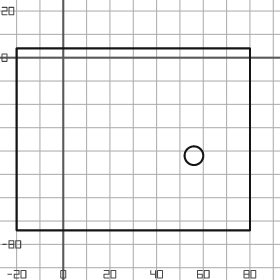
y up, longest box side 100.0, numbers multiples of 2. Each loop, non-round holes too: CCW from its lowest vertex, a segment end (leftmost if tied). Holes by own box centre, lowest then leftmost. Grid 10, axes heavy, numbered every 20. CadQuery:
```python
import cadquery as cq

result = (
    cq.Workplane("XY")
    .moveTo(-20.0, -74.0)
    .lineTo(80.0, -74.0)
    .lineTo(80.0, 4.0)
    .lineTo(-20.0, 4.0)
    .close()
    .moveTo(56.0, -42.0)
    .circle(4.0)
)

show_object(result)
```